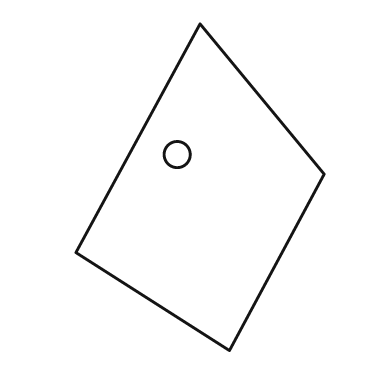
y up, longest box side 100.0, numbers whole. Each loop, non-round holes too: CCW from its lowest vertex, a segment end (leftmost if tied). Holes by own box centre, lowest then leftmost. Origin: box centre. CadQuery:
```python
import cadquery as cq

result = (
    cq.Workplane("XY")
    .moveTo(9.0, -50.0)
    .lineTo(38.0, 4.0)
    .lineTo(0.0, 50.0)
    .lineTo(-38.0, -20.0)
    .close()
    .moveTo(-7.0, 10.0)
    .circle(4.0)
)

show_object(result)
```